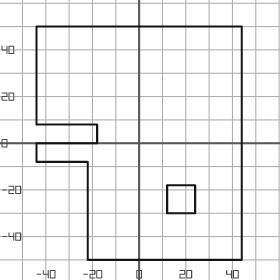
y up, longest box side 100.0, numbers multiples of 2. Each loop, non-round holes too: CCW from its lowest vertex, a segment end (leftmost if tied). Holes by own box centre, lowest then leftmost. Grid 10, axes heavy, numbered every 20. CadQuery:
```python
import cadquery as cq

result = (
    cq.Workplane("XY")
    .moveTo(-22.0, -50.0)
    .lineTo(44.0, -50.0)
    .lineTo(44.0, 50.0)
    .lineTo(-44.0, 50.0)
    .lineTo(-44.0, 8.0)
    .lineTo(-18.0, 8.0)
    .lineTo(-18.0, 0.0)
    .lineTo(-44.0, 0.0)
    .lineTo(-44.0, -8.0)
    .lineTo(-22.0, -8.0)
    .close()
    .moveTo(12.0, -30.0)
    .lineTo(24.0, -30.0)
    .lineTo(24.0, -18.0)
    .lineTo(12.0, -18.0)
    .close()
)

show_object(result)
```